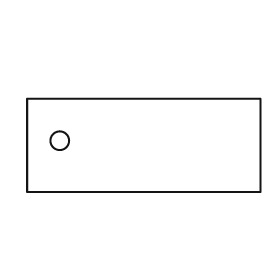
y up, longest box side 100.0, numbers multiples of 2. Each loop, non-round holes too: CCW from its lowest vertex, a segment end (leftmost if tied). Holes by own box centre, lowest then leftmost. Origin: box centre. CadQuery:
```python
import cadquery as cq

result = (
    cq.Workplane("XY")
    .moveTo(-50.0, -20.0)
    .lineTo(50.0, -20.0)
    .lineTo(50.0, 20.0)
    .lineTo(-50.0, 20.0)
    .close()
    .moveTo(-36.0, 2.0)
    .circle(4.0)
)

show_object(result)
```